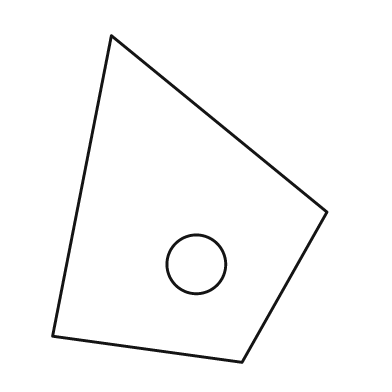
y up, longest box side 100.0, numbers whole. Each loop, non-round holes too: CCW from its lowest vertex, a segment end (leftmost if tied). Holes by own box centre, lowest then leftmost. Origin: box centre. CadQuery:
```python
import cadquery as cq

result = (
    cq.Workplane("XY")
    .moveTo(16.0, -50.0)
    .lineTo(42.0, -4.0)
    .lineTo(-24.0, 50.0)
    .lineTo(-42.0, -42.0)
    .close()
    .moveTo(2.0, -20.0)
    .circle(9.0)
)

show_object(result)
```